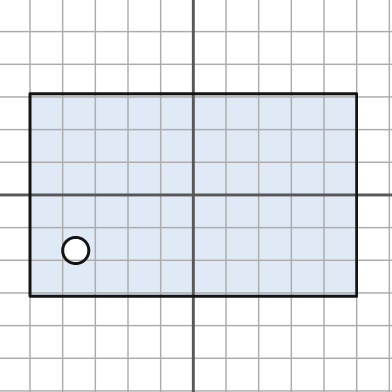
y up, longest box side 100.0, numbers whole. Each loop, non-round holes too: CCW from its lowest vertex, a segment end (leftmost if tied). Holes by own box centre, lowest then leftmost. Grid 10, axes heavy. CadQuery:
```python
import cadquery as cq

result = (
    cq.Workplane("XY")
    .moveTo(-50.0, -31.0)
    .lineTo(50.0, -31.0)
    .lineTo(50.0, 31.0)
    .lineTo(-50.0, 31.0)
    .close()
    .moveTo(-36.0, -17.0)
    .circle(4.0)
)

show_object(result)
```